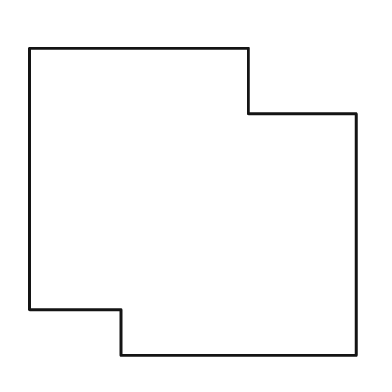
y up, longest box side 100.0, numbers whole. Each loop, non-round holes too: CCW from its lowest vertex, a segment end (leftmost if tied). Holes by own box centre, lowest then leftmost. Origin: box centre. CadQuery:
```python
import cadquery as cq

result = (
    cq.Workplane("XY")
    .moveTo(-22.0, -47.0)
    .lineTo(50.0, -47.0)
    .lineTo(50.0, 27.0)
    .lineTo(17.0, 27.0)
    .lineTo(17.0, 47.0)
    .lineTo(-50.0, 47.0)
    .lineTo(-50.0, -33.0)
    .lineTo(-22.0, -33.0)
    .close()
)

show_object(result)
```